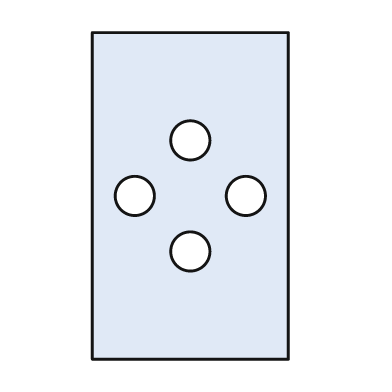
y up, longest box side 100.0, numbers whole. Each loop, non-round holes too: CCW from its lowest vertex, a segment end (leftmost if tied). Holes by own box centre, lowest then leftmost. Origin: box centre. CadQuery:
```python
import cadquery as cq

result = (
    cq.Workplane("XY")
    .moveTo(-30.0, -50.0)
    .lineTo(30.0, -50.0)
    .lineTo(30.0, 50.0)
    .lineTo(-30.0, 50.0)
    .close()
    .moveTo(0.0, -17.0)
    .circle(6.0)
    .moveTo(-17.0, 0.0)
    .circle(6.0)
    .moveTo(17.0, 0.0)
    .circle(6.0)
    .moveTo(0.0, 17.0)
    .circle(6.0)
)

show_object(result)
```